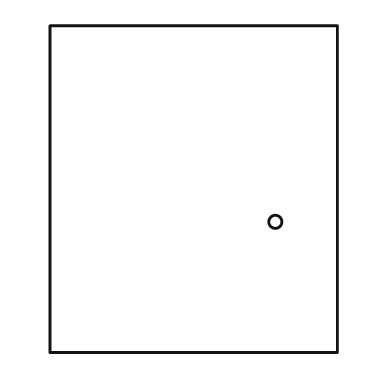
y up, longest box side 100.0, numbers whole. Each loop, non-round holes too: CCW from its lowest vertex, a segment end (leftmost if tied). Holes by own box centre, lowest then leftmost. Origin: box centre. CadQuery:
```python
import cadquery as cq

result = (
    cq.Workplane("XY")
    .moveTo(-44.0, -50.0)
    .lineTo(44.0, -50.0)
    .lineTo(44.0, 50.0)
    .lineTo(-44.0, 50.0)
    .close()
    .moveTo(25.0, -10.0)
    .circle(2.0)
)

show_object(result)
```